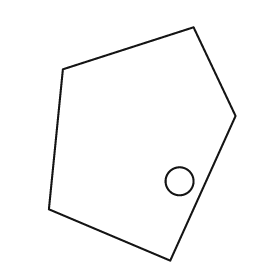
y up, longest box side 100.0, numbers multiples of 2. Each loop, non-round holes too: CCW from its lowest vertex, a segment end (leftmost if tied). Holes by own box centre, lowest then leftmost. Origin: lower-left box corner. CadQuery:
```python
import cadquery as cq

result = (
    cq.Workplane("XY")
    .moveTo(52.0, 0.0)
    .lineTo(80.0, 62.0)
    .lineTo(62.0, 100.0)
    .lineTo(6.0, 82.0)
    .lineTo(0.0, 22.0)
    .close()
    .moveTo(56.0, 34.0)
    .circle(6.0)
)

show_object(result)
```